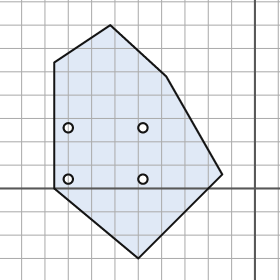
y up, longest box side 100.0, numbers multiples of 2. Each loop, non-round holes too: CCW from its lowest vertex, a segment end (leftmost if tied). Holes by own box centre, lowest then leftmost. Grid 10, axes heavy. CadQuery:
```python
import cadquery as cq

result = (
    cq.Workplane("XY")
    .moveTo(-50.0, -30.0)
    .lineTo(-14.0, 6.0)
    .lineTo(-38.0, 48.0)
    .lineTo(-62.0, 70.0)
    .lineTo(-86.0, 54.0)
    .lineTo(-86.0, 0.0)
    .close()
    .moveTo(-80.0, 4.0)
    .circle(2.0)
    .moveTo(-48.0, 4.0)
    .circle(2.0)
    .moveTo(-80.0, 26.0)
    .circle(2.0)
    .moveTo(-48.0, 26.0)
    .circle(2.0)
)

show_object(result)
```